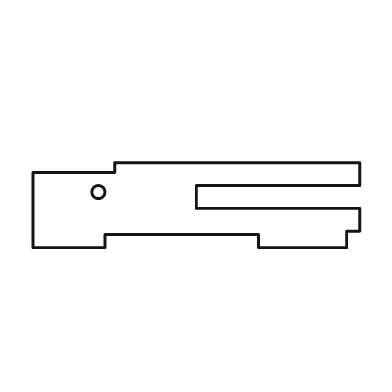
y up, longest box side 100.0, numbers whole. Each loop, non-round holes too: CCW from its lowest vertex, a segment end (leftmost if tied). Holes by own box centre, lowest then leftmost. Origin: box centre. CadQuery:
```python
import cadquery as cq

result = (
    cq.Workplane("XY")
    .moveTo(-50.0, -13.0)
    .lineTo(-28.0, -13.0)
    .lineTo(-28.0, -9.0)
    .lineTo(19.0, -9.0)
    .lineTo(19.0, -13.0)
    .lineTo(46.0, -13.0)
    .lineTo(46.0, -8.0)
    .lineTo(50.0, -8.0)
    .lineTo(50.0, -1.0)
    .lineTo(0.0, -1.0)
    .lineTo(0.0, 6.0)
    .lineTo(50.0, 6.0)
    .lineTo(50.0, 13.0)
    .lineTo(-25.0, 13.0)
    .lineTo(-25.0, 10.0)
    .lineTo(-50.0, 10.0)
    .close()
    .moveTo(-30.0, 4.0)
    .circle(2.0)
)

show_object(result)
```